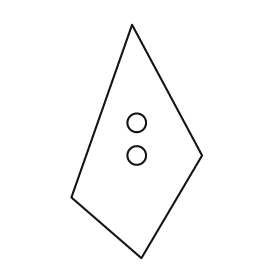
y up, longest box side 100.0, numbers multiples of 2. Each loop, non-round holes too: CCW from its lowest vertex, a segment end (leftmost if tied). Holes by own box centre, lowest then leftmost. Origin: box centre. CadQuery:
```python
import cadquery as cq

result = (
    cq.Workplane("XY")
    .moveTo(2.0, -50.0)
    .lineTo(28.0, -6.0)
    .lineTo(-2.0, 50.0)
    .lineTo(-28.0, -24.0)
    .close()
    .moveTo(0.0, -6.0)
    .circle(4.0)
    .moveTo(0.0, 8.0)
    .circle(4.0)
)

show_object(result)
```